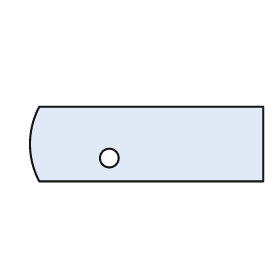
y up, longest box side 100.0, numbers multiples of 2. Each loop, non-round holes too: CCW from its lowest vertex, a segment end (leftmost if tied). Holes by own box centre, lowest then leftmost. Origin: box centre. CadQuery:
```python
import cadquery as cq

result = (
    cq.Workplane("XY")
    .moveTo(-46.0, -16.0)
    .lineTo(50.0, -16.0)
    .lineTo(50.0, 16.0)
    .lineTo(-46.0, 16.0)
    .threePointArc((-50.0, 0.0), (-46.0, -16.0))
    .close()
    .moveTo(-16.0, -6.0)
    .circle(4.0)
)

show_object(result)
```